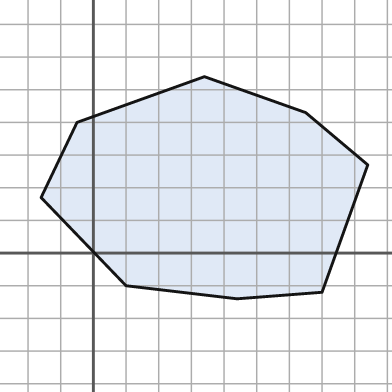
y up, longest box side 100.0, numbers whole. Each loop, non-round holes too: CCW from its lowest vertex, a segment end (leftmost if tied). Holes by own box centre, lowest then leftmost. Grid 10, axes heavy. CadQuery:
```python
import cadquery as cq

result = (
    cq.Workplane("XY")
    .moveTo(44.0, -14.0)
    .lineTo(70.0, -12.0)
    .lineTo(84.0, 27.0)
    .lineTo(65.0, 43.0)
    .lineTo(34.0, 54.0)
    .lineTo(-5.0, 40.0)
    .lineTo(-16.0, 17.0)
    .lineTo(10.0, -10.0)
    .close()
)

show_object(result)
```